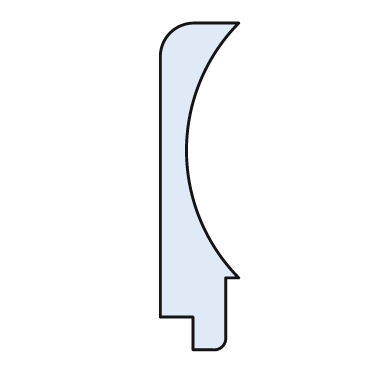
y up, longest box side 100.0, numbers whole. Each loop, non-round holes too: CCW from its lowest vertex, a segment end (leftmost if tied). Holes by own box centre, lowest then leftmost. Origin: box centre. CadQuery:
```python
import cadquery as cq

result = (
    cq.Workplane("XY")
    .moveTo(-2.0, -50.0)
    .lineTo(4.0, -50.0)
    .threePointArc((7.0, -49.0), (8.0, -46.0))
    .lineTo(8.0, -28.0)
    .lineTo(12.0, -28.0)
    .threePointArc((-4.0, 11.0), (12.0, 50.0))
    .lineTo(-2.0, 50.0)
    .threePointArc((-9.0, 47.0), (-12.0, 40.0))
    .lineTo(-12.0, -40.0)
    .lineTo(-2.0, -40.0)
    .close()
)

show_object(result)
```